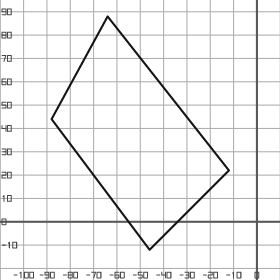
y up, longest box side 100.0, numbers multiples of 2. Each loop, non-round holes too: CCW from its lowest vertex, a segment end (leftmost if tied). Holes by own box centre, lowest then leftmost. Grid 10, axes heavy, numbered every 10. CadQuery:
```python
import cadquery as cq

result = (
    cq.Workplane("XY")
    .moveTo(-46.0, -12.0)
    .lineTo(-12.0, 22.0)
    .lineTo(-64.0, 88.0)
    .lineTo(-88.0, 44.0)
    .close()
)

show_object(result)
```